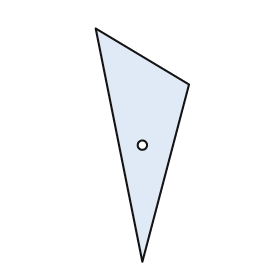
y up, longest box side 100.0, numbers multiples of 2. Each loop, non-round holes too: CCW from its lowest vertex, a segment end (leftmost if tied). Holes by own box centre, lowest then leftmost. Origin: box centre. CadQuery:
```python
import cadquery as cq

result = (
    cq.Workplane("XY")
    .moveTo(0.0, -50.0)
    .lineTo(20.0, 26.0)
    .lineTo(-20.0, 50.0)
    .close()
    .moveTo(0.0, 0.0)
    .circle(2.0)
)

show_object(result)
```